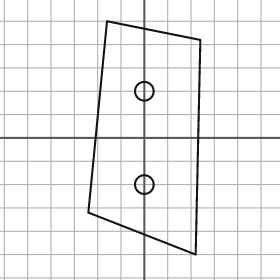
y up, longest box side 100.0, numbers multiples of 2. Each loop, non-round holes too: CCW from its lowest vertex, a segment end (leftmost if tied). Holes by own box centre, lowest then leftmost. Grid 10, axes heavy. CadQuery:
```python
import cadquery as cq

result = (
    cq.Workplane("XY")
    .moveTo(22.0, -50.0)
    .lineTo(24.0, 42.0)
    .lineTo(-16.0, 50.0)
    .lineTo(-24.0, -32.0)
    .close()
    .moveTo(0.0, -20.0)
    .circle(4.0)
    .moveTo(0.0, 20.0)
    .circle(4.0)
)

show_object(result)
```